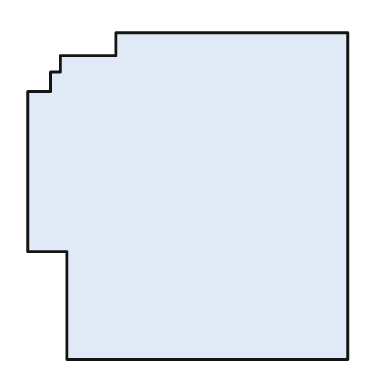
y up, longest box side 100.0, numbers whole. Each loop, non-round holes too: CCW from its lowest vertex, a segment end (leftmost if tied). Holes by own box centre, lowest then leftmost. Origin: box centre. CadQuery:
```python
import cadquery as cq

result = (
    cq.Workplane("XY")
    .moveTo(-37.0, -50.0)
    .lineTo(49.0, -50.0)
    .lineTo(49.0, 50.0)
    .lineTo(-22.0, 50.0)
    .lineTo(-22.0, 43.0)
    .lineTo(-39.0, 43.0)
    .lineTo(-39.0, 38.0)
    .lineTo(-42.0, 38.0)
    .lineTo(-42.0, 32.0)
    .lineTo(-49.0, 32.0)
    .lineTo(-49.0, -17.0)
    .lineTo(-37.0, -17.0)
    .close()
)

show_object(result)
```